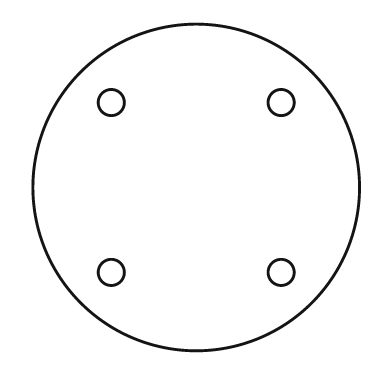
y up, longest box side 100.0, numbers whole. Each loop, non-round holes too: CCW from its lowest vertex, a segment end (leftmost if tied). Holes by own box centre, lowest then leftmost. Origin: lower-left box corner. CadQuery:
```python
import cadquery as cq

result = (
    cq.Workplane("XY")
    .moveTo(50.0, 50.0)
    .circle(50.0)
    .moveTo(24.0, 24.0)
    .circle(4.0)
    .moveTo(76.0, 24.0)
    .circle(4.0)
    .moveTo(24.0, 76.0)
    .circle(4.0)
    .moveTo(76.0, 76.0)
    .circle(4.0)
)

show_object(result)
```